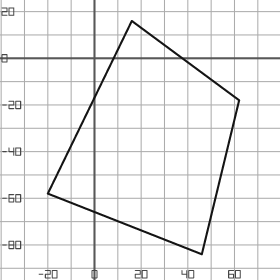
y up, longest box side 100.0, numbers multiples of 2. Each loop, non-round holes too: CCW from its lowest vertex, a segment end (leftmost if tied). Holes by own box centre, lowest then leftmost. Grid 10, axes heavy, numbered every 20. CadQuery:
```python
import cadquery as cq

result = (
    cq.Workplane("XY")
    .moveTo(46.0, -84.0)
    .lineTo(62.0, -18.0)
    .lineTo(16.0, 16.0)
    .lineTo(-20.0, -58.0)
    .close()
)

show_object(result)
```